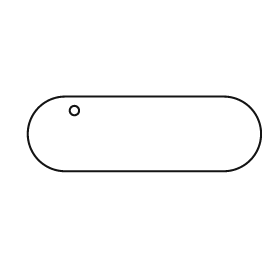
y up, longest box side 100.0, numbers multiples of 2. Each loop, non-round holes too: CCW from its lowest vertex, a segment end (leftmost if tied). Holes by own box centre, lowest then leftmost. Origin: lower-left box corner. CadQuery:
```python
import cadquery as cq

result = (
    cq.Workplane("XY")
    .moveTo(16.0, 0.0)
    .lineTo(84.0, 0.0)
    .threePointArc((100.0, 16.0), (84.0, 32.0))
    .lineTo(16.0, 32.0)
    .threePointArc((0.0, 16.0), (16.0, 0.0))
    .close()
    .moveTo(20.0, 26.0)
    .circle(2.0)
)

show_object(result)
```